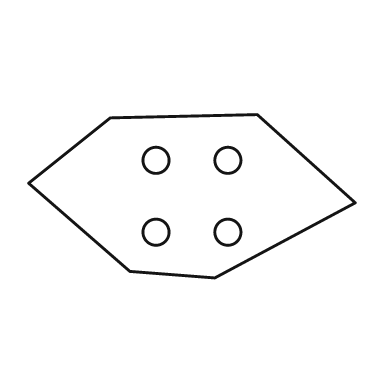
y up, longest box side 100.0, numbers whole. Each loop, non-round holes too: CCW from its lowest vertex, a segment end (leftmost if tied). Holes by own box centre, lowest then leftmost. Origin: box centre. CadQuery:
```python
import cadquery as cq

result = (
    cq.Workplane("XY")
    .moveTo(7.0, -25.0)
    .lineTo(50.0, -2.0)
    .lineTo(20.0, 25.0)
    .lineTo(-25.0, 24.0)
    .lineTo(-50.0, 4.0)
    .lineTo(-19.0, -23.0)
    .close()
    .moveTo(-11.0, -11.0)
    .circle(4.0)
    .moveTo(11.0, -11.0)
    .circle(4.0)
    .moveTo(-11.0, 11.0)
    .circle(4.0)
    .moveTo(11.0, 11.0)
    .circle(4.0)
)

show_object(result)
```